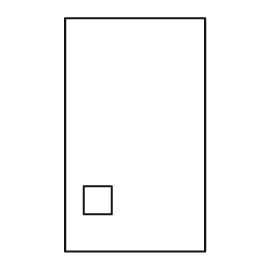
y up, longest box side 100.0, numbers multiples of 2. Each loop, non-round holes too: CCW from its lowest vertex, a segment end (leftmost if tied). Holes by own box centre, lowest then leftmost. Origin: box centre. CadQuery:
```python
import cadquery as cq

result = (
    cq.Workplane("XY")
    .moveTo(-30.0, -50.0)
    .lineTo(30.0, -50.0)
    .lineTo(30.0, 50.0)
    .lineTo(-30.0, 50.0)
    .close()
    .moveTo(-22.0, -34.0)
    .lineTo(-10.0, -34.0)
    .lineTo(-10.0, -22.0)
    .lineTo(-22.0, -22.0)
    .close()
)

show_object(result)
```